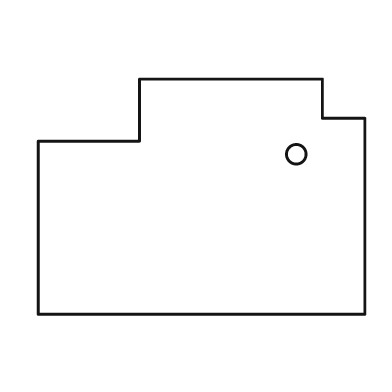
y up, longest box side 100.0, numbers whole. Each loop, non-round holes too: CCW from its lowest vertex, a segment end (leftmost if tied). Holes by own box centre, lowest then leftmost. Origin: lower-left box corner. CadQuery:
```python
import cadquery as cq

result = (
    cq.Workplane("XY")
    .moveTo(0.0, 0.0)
    .lineTo(100.0, 0.0)
    .lineTo(100.0, 60.0)
    .lineTo(87.0, 60.0)
    .lineTo(87.0, 72.0)
    .lineTo(31.0, 72.0)
    .lineTo(31.0, 53.0)
    .lineTo(0.0, 53.0)
    .close()
    .moveTo(79.0, 49.0)
    .circle(3.0)
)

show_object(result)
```